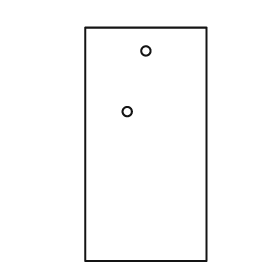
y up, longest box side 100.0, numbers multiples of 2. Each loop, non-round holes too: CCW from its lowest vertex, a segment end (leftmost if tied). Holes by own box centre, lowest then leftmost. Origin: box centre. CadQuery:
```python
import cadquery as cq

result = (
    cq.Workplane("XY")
    .moveTo(-26.0, -50.0)
    .lineTo(26.0, -50.0)
    .lineTo(26.0, 50.0)
    .lineTo(-26.0, 50.0)
    .close()
    .moveTo(-8.0, 14.0)
    .circle(2.0)
    .moveTo(0.0, 40.0)
    .circle(2.0)
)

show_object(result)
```